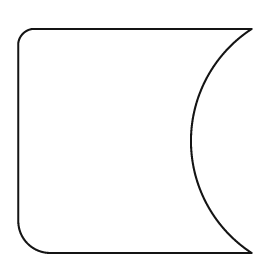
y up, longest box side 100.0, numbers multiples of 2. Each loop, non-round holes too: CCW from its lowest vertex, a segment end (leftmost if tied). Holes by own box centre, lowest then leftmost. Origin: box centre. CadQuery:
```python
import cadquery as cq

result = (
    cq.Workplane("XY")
    .moveTo(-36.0, -48.0)
    .lineTo(50.0, -48.0)
    .threePointArc((24.0, 0.0), (50.0, 48.0))
    .lineTo(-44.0, 48.0)
    .threePointArc((-48.0, 46.0), (-50.0, 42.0))
    .lineTo(-50.0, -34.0)
    .threePointArc((-46.0, -44.0), (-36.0, -48.0))
    .close()
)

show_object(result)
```